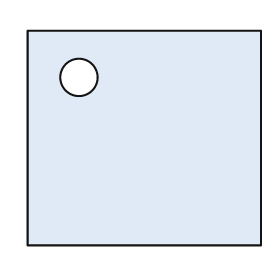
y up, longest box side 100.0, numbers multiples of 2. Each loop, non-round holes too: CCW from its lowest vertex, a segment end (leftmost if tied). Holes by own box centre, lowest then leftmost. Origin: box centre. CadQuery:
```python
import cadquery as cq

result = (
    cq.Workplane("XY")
    .moveTo(-50.0, -46.0)
    .lineTo(50.0, -46.0)
    .lineTo(50.0, 46.0)
    .lineTo(-50.0, 46.0)
    .close()
    .moveTo(-28.0, 26.0)
    .circle(8.0)
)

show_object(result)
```